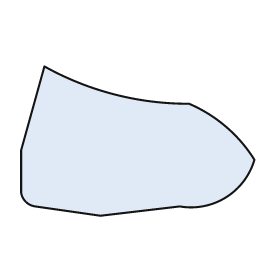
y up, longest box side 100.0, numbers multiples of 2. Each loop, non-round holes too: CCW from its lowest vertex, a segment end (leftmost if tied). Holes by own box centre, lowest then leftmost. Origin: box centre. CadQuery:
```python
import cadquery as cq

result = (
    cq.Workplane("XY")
    .moveTo(-16.0, -32.0)
    .lineTo(18.0, -28.0)
    .threePointArc((38.0, -24.0), (50.0, -8.0))
    .threePointArc((38.0, 6.0), (22.0, 16.0))
    .threePointArc((-10.0, 20.0), (-40.0, 32.0))
    .lineTo(-50.0, -4.0)
    .lineTo(-50.0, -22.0)
    .threePointArc((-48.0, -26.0), (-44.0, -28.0))
    .close()
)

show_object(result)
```